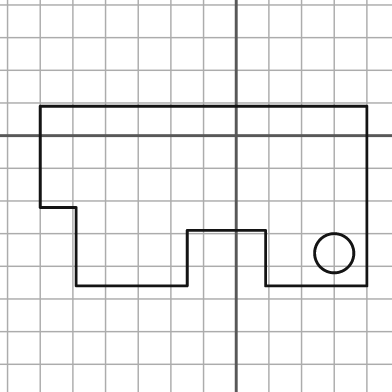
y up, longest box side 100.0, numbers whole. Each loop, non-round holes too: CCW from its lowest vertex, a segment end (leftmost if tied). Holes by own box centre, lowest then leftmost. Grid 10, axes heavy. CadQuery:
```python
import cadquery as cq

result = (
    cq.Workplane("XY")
    .moveTo(-49.0, -46.0)
    .lineTo(-15.0, -46.0)
    .lineTo(-15.0, -29.0)
    .lineTo(9.0, -29.0)
    .lineTo(9.0, -46.0)
    .lineTo(40.0, -46.0)
    .lineTo(40.0, 9.0)
    .lineTo(-60.0, 9.0)
    .lineTo(-60.0, -22.0)
    .lineTo(-49.0, -22.0)
    .close()
    .moveTo(30.0, -36.0)
    .circle(6.0)
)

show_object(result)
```